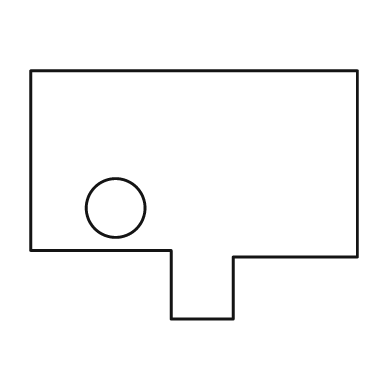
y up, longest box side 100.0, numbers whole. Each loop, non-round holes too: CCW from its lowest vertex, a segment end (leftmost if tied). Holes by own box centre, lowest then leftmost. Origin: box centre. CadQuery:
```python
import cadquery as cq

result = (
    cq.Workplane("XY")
    .moveTo(-7.0, -38.0)
    .lineTo(12.0, -38.0)
    .lineTo(12.0, -19.0)
    .lineTo(50.0, -19.0)
    .lineTo(50.0, 38.0)
    .lineTo(-50.0, 38.0)
    .lineTo(-50.0, -17.0)
    .lineTo(-7.0, -17.0)
    .close()
    .moveTo(-24.0, -4.0)
    .circle(9.0)
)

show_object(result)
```